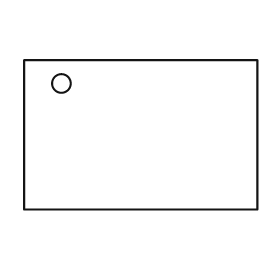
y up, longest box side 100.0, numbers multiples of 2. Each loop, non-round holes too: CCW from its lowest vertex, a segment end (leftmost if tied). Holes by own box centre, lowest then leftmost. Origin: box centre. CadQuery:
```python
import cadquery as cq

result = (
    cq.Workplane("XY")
    .moveTo(-50.0, -32.0)
    .lineTo(50.0, -32.0)
    .lineTo(50.0, 32.0)
    .lineTo(-50.0, 32.0)
    .close()
    .moveTo(-34.0, 22.0)
    .circle(4.0)
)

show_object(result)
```